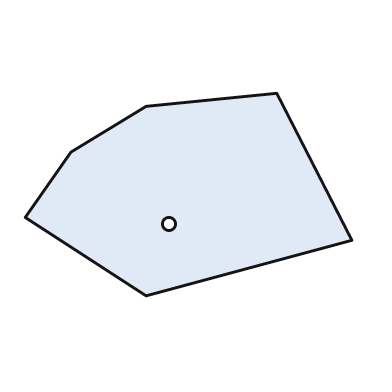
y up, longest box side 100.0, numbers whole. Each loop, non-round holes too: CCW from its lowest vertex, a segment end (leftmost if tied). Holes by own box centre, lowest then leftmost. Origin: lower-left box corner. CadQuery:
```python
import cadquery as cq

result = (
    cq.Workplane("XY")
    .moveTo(37.0, 0.0)
    .lineTo(100.0, 17.0)
    .lineTo(77.0, 62.0)
    .lineTo(37.0, 58.0)
    .lineTo(14.0, 44.0)
    .lineTo(0.0, 24.0)
    .close()
    .moveTo(44.0, 22.0)
    .circle(2.0)
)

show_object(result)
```